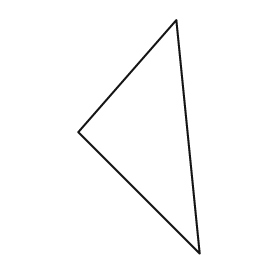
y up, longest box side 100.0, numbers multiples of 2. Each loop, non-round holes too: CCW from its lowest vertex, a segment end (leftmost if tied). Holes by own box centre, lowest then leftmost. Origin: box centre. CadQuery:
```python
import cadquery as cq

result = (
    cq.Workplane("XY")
    .moveTo(26.0, -50.0)
    .lineTo(16.0, 50.0)
    .lineTo(-26.0, 2.0)
    .close()
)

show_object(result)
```